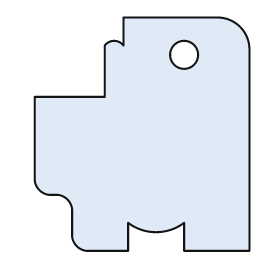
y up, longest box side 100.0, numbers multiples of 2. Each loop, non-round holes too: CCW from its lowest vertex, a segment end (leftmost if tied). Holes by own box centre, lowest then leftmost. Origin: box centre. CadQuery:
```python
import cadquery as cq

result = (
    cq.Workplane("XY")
    .moveTo(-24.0, -50.0)
    .lineTo(-6.0, -50.0)
    .lineTo(-6.0, -38.0)
    .threePointArc((6.0, -42.0), (18.0, -38.0))
    .lineTo(18.0, -50.0)
    .lineTo(46.0, -50.0)
    .lineTo(46.0, 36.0)
    .threePointArc((42.0, 46.0), (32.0, 50.0))
    .lineTo(-8.0, 50.0)
    .lineTo(-8.0, 38.0)
    .threePointArc((-12.0, 40.0), (-16.0, 38.0))
    .lineTo(-16.0, 16.0)
    .lineTo(-46.0, 16.0)
    .lineTo(-46.0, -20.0)
    .threePointArc((-44.0, -24.0), (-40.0, -26.0))
    .lineTo(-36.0, -26.0)
    .threePointArc((-32.0, -28.0), (-30.0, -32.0))
    .lineTo(-30.0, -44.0)
    .threePointArc((-28.0, -48.0), (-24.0, -50.0))
    .close()
    .moveTo(18.0, 34.0)
    .circle(6.0)
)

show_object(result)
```